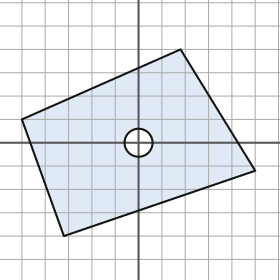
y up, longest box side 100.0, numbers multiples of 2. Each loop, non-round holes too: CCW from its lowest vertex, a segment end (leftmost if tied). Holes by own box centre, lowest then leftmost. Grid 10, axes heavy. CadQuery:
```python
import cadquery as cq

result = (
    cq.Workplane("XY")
    .moveTo(-32.0, -40.0)
    .lineTo(50.0, -12.0)
    .lineTo(18.0, 40.0)
    .lineTo(-50.0, 10.0)
    .close()
    .moveTo(0.0, 0.0)
    .circle(6.0)
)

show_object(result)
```